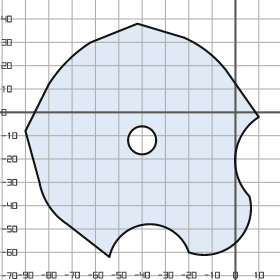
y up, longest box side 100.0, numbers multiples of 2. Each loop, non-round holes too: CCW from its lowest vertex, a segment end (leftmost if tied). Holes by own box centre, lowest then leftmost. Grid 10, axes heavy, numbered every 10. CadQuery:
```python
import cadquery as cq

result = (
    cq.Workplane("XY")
    .moveTo(-54.0, -62.0)
    .threePointArc((-38.0, -48.0), (-20.0, -60.0))
    .threePointArc((0.0, -56.0), (6.0, -36.0))
    .threePointArc((0.0, -18.0), (10.0, -2.0))
    .lineTo(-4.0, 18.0)
    .threePointArc((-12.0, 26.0), (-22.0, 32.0))
    .lineTo(-42.0, 38.0)
    .lineTo(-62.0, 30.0)
    .threePointArc((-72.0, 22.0), (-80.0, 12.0))
    .lineTo(-90.0, -8.0)
    .lineTo(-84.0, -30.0)
    .threePointArc((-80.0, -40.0), (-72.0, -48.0))
    .close()
    .moveTo(-40.0, -12.0)
    .circle(6.0)
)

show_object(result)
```